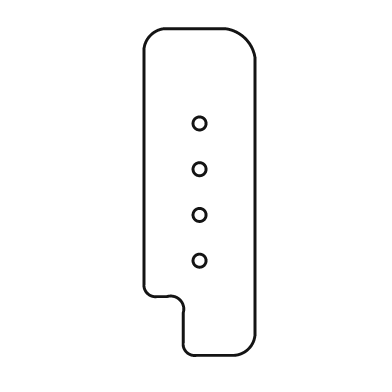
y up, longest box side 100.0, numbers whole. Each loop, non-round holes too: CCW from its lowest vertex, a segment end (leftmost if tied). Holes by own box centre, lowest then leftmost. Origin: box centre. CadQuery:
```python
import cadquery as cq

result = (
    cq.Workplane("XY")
    .moveTo(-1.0, -50.0)
    .lineTo(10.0, -50.0)
    .threePointArc((15.0, -48.0), (17.0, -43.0))
    .lineTo(17.0, 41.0)
    .threePointArc((14.0, 47.0), (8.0, 50.0))
    .lineTo(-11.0, 50.0)
    .threePointArc((-15.0, 48.0), (-17.0, 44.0))
    .lineTo(-17.0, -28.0)
    .threePointArc((-16.0, -31.0), (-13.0, -32.0))
    .lineTo(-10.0, -32.0)
    .threePointArc((-6.0, -33.0), (-5.0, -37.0))
    .lineTo(-5.0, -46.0)
    .threePointArc((-4.0, -49.0), (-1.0, -50.0))
    .close()
    .moveTo(0.0, -21.0)
    .circle(2.0)
    .moveTo(0.0, -7.0)
    .circle(2.0)
    .moveTo(0.0, 7.0)
    .circle(2.0)
    .moveTo(0.0, 21.0)
    .circle(2.0)
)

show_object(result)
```